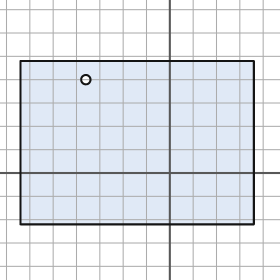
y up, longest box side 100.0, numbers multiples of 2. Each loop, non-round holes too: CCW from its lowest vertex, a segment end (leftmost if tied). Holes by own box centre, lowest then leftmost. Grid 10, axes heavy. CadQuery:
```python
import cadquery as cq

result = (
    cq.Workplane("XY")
    .moveTo(-64.0, -22.0)
    .lineTo(36.0, -22.0)
    .lineTo(36.0, 48.0)
    .lineTo(-64.0, 48.0)
    .close()
    .moveTo(-36.0, 40.0)
    .circle(2.0)
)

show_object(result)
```